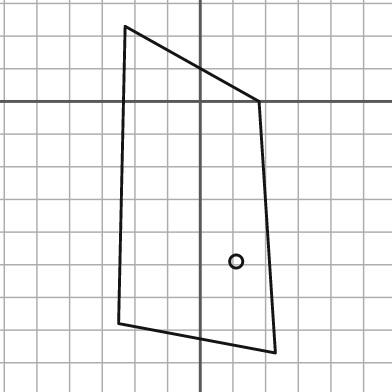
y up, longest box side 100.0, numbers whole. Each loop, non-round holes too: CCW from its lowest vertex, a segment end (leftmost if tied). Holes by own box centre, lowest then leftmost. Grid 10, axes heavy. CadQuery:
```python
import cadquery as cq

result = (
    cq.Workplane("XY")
    .moveTo(23.0, -77.0)
    .lineTo(18.0, 0.0)
    .lineTo(-23.0, 23.0)
    .lineTo(-25.0, -68.0)
    .close()
    .moveTo(11.0, -49.0)
    .circle(2.0)
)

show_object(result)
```